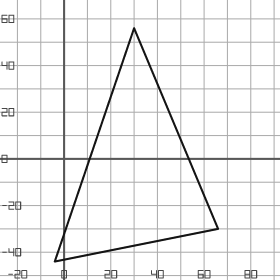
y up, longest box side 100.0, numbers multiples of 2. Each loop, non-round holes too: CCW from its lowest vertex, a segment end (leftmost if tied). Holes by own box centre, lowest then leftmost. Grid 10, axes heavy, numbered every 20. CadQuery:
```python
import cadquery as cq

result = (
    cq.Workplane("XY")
    .moveTo(-4.0, -44.0)
    .lineTo(66.0, -30.0)
    .lineTo(30.0, 56.0)
    .close()
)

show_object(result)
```